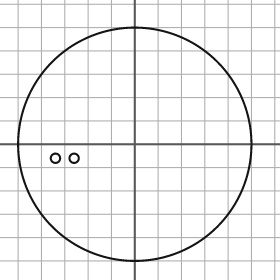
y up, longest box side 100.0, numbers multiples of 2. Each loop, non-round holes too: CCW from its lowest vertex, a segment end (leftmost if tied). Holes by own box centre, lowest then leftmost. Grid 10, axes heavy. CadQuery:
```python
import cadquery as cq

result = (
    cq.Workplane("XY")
    .moveTo(0.0, 0.0)
    .circle(50.0)
    .moveTo(-34.0, -6.0)
    .circle(2.0)
    .moveTo(-26.0, -6.0)
    .circle(2.0)
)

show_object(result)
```